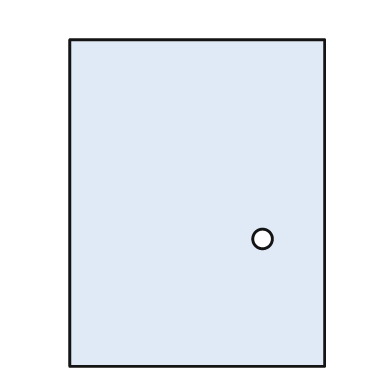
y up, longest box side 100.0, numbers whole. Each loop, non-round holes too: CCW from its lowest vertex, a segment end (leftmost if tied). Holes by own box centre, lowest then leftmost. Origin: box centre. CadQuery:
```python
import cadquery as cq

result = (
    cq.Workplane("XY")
    .moveTo(-39.0, -50.0)
    .lineTo(39.0, -50.0)
    .lineTo(39.0, 50.0)
    .lineTo(-39.0, 50.0)
    .close()
    .moveTo(20.0, -11.0)
    .circle(3.0)
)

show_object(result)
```